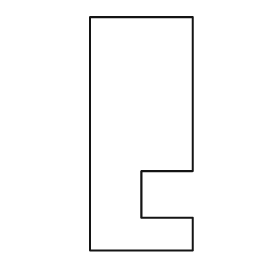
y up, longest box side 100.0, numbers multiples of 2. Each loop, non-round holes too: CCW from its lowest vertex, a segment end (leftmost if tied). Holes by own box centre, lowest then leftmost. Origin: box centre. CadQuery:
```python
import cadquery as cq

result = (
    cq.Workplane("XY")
    .moveTo(-22.0, -50.0)
    .lineTo(22.0, -50.0)
    .lineTo(22.0, -36.0)
    .lineTo(0.0, -36.0)
    .lineTo(0.0, -16.0)
    .lineTo(22.0, -16.0)
    .lineTo(22.0, 50.0)
    .lineTo(-22.0, 50.0)
    .close()
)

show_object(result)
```